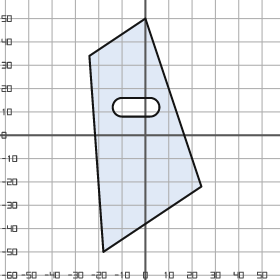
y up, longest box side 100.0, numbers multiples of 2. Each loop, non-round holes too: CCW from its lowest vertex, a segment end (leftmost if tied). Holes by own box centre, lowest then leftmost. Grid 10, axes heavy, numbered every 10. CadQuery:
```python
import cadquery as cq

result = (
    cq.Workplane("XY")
    .moveTo(-18.0, -50.0)
    .lineTo(24.0, -22.0)
    .lineTo(0.0, 50.0)
    .lineTo(-24.0, 34.0)
    .close()
    .moveTo(-10.0, 8.0)
    .lineTo(2.0, 8.0)
    .threePointArc((6.0, 12.0), (2.0, 16.0))
    .lineTo(-10.0, 16.0)
    .threePointArc((-14.0, 12.0), (-10.0, 8.0))
    .close()
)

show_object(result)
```